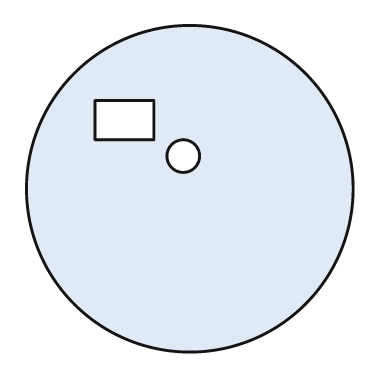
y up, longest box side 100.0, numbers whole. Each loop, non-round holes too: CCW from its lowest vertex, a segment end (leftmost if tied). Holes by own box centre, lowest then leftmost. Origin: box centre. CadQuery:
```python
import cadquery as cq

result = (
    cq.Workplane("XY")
    .moveTo(0.0, 0.0)
    .circle(50.0)
    .moveTo(-2.0, 10.0)
    .circle(5.0)
    .moveTo(-29.0, 15.0)
    .lineTo(-11.0, 15.0)
    .lineTo(-11.0, 27.0)
    .lineTo(-29.0, 27.0)
    .close()
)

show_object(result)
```